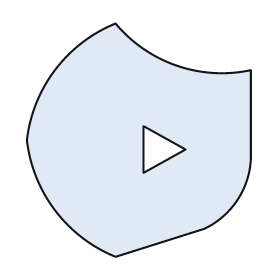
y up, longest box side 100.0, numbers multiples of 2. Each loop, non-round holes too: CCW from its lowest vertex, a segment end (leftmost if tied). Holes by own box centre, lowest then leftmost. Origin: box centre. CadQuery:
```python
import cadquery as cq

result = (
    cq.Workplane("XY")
    .moveTo(-10.0, -50.0)
    .lineTo(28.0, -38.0)
    .threePointArc((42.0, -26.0), (48.0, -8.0))
    .lineTo(48.0, 30.0)
    .threePointArc((16.0, 32.0), (-10.0, 50.0))
    .threePointArc((-36.0, 30.0), (-48.0, 0.0))
    .threePointArc((-36.0, -30.0), (-10.0, -50.0))
    .close()
    .moveTo(2.0, -14.0)
    .lineTo(20.0, -4.0)
    .lineTo(2.0, 6.0)
    .close()
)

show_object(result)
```